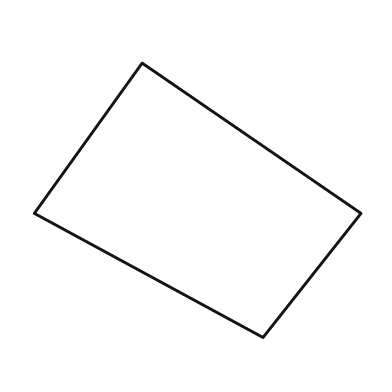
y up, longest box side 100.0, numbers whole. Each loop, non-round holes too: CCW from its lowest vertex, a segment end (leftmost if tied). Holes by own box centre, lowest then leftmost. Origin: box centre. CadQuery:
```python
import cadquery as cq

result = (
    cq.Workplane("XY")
    .moveTo(20.0, -42.0)
    .lineTo(50.0, -4.0)
    .lineTo(-17.0, 42.0)
    .lineTo(-50.0, -4.0)
    .close()
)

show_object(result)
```